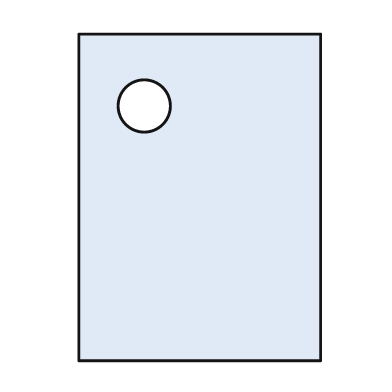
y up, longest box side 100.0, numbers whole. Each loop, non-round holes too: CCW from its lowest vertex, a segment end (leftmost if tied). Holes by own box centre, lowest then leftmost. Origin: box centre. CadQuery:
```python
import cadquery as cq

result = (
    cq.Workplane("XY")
    .moveTo(-37.0, -50.0)
    .lineTo(37.0, -50.0)
    .lineTo(37.0, 50.0)
    .lineTo(-37.0, 50.0)
    .close()
    .moveTo(-17.0, 28.0)
    .circle(8.0)
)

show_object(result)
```